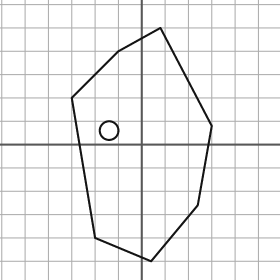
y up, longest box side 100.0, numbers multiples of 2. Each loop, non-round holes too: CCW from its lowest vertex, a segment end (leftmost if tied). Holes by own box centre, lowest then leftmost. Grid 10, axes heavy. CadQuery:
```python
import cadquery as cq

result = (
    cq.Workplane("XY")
    .moveTo(4.0, -50.0)
    .lineTo(24.0, -26.0)
    .lineTo(30.0, 8.0)
    .lineTo(8.0, 50.0)
    .lineTo(-10.0, 40.0)
    .lineTo(-30.0, 20.0)
    .lineTo(-20.0, -40.0)
    .close()
    .moveTo(-14.0, 6.0)
    .circle(4.0)
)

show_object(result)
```